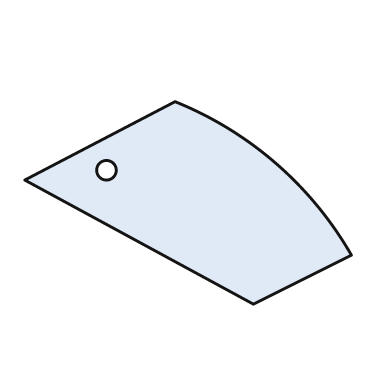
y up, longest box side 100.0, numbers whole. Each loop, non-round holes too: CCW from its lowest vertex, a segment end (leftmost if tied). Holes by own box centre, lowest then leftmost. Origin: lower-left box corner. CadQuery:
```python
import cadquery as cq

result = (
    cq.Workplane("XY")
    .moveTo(70.0, 0.0)
    .lineTo(100.0, 15.0)
    .threePointArc((77.0, 43.0), (46.0, 62.0))
    .lineTo(0.0, 38.0)
    .close()
    .moveTo(25.0, 41.0)
    .circle(3.0)
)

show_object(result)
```